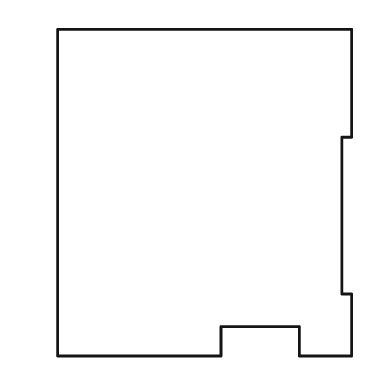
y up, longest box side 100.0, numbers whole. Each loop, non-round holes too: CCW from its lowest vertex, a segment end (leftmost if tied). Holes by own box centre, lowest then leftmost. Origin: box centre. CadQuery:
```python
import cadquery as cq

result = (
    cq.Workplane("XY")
    .moveTo(-45.0, -50.0)
    .lineTo(5.0, -50.0)
    .lineTo(5.0, -41.0)
    .lineTo(29.0, -41.0)
    .lineTo(29.0, -50.0)
    .lineTo(45.0, -50.0)
    .lineTo(45.0, -31.0)
    .lineTo(42.0, -31.0)
    .lineTo(42.0, 17.0)
    .lineTo(45.0, 17.0)
    .lineTo(45.0, 50.0)
    .lineTo(-45.0, 50.0)
    .close()
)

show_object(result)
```